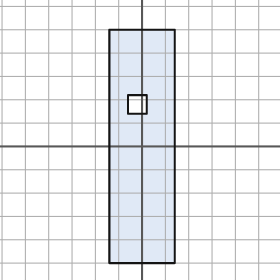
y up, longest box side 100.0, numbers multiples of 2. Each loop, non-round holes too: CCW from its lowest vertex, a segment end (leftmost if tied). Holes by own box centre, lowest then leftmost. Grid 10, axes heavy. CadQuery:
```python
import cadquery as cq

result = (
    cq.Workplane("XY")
    .moveTo(-14.0, -50.0)
    .lineTo(14.0, -50.0)
    .lineTo(14.0, 50.0)
    .lineTo(-14.0, 50.0)
    .close()
    .moveTo(-6.0, 14.0)
    .lineTo(2.0, 14.0)
    .lineTo(2.0, 22.0)
    .lineTo(-6.0, 22.0)
    .close()
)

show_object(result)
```